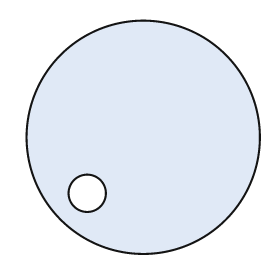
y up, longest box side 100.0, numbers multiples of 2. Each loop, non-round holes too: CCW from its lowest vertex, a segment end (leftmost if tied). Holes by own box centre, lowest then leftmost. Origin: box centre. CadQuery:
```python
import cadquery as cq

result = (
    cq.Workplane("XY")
    .moveTo(0.0, 0.0)
    .circle(50.0)
    .moveTo(-24.0, -24.0)
    .circle(8.0)
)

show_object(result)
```